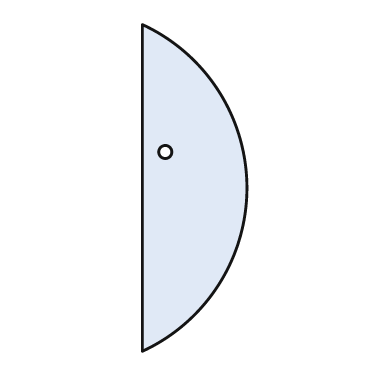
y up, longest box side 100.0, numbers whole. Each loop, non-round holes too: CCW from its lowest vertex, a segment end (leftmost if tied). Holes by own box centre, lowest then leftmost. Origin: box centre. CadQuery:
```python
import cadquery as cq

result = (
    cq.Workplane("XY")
    .moveTo(-16.0, -50.0)
    .threePointArc((16.0, 0.0), (-16.0, 50.0))
    .close()
    .moveTo(-9.0, 11.0)
    .circle(2.0)
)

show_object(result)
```